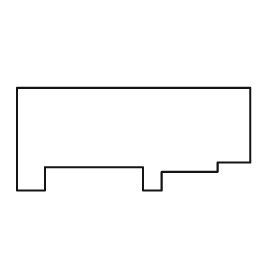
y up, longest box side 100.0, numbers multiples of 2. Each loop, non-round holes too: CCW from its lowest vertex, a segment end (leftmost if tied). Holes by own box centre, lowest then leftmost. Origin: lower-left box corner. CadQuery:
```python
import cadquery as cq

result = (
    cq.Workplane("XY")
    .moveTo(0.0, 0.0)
    .lineTo(12.0, 0.0)
    .lineTo(12.0, 10.0)
    .lineTo(54.0, 10.0)
    .lineTo(54.0, 0.0)
    .lineTo(62.0, 0.0)
    .lineTo(62.0, 8.0)
    .lineTo(86.0, 8.0)
    .lineTo(86.0, 12.0)
    .lineTo(100.0, 12.0)
    .lineTo(100.0, 44.0)
    .lineTo(0.0, 44.0)
    .close()
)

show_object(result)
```